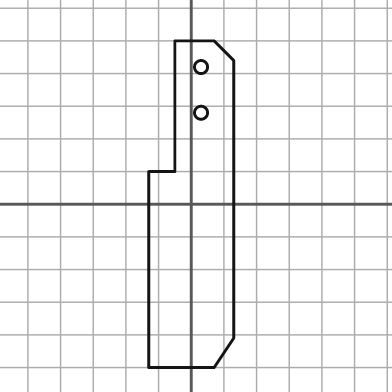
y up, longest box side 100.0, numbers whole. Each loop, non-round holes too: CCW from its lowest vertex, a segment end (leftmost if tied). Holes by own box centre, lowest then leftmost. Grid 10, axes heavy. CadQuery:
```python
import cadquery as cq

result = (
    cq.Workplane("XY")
    .moveTo(-13.0, -50.0)
    .lineTo(7.0, -50.0)
    .lineTo(13.0, -41.0)
    .lineTo(13.0, 44.0)
    .lineTo(7.0, 50.0)
    .lineTo(-5.0, 50.0)
    .lineTo(-5.0, 10.0)
    .lineTo(-13.0, 10.0)
    .close()
    .moveTo(3.0, 28.0)
    .circle(2.0)
    .moveTo(3.0, 42.0)
    .circle(2.0)
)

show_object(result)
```